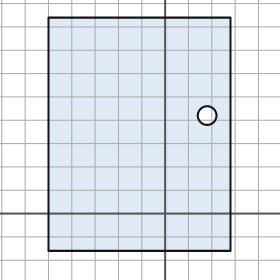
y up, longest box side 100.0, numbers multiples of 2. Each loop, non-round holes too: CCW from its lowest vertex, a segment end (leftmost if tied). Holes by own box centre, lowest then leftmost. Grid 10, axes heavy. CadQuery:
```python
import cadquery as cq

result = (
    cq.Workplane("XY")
    .moveTo(-50.0, -16.0)
    .lineTo(28.0, -16.0)
    .lineTo(28.0, 84.0)
    .lineTo(-50.0, 84.0)
    .close()
    .moveTo(18.0, 42.0)
    .circle(4.0)
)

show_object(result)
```